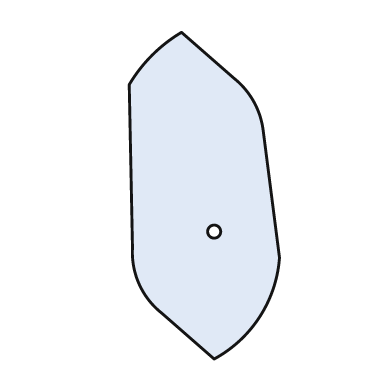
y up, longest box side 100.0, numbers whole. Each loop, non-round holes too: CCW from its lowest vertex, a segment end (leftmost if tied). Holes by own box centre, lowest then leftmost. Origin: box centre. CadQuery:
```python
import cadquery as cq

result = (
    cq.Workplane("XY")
    .moveTo(3.0, -50.0)
    .threePointArc((17.0, -37.0), (23.0, -19.0))
    .lineTo(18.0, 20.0)
    .threePointArc((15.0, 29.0), (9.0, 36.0))
    .lineTo(-7.0, 50.0)
    .threePointArc((-16.0, 43.0), (-23.0, 34.0))
    .lineTo(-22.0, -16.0)
    .threePointArc((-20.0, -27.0), (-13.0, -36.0))
    .close()
    .moveTo(3.0, -11.0)
    .circle(2.0)
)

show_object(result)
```